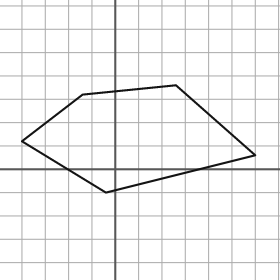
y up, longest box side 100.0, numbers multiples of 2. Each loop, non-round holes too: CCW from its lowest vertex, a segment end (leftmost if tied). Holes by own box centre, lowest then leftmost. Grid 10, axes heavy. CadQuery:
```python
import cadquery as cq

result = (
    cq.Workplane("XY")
    .moveTo(-4.0, -10.0)
    .lineTo(60.0, 6.0)
    .lineTo(26.0, 36.0)
    .lineTo(-14.0, 32.0)
    .lineTo(-40.0, 12.0)
    .close()
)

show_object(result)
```